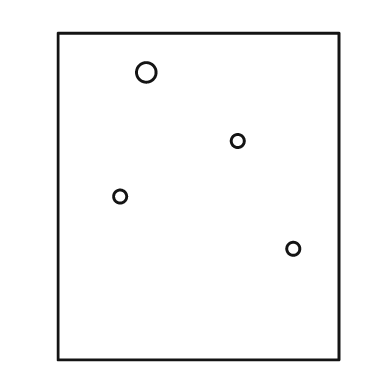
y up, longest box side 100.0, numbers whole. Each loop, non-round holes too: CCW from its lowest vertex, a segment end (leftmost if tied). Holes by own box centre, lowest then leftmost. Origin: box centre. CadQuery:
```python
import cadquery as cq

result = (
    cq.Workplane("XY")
    .moveTo(-43.0, -50.0)
    .lineTo(43.0, -50.0)
    .lineTo(43.0, 50.0)
    .lineTo(-43.0, 50.0)
    .close()
    .moveTo(29.0, -16.0)
    .circle(2.0)
    .moveTo(-24.0, 0.0)
    .circle(2.0)
    .moveTo(12.0, 17.0)
    .circle(2.0)
    .moveTo(-16.0, 38.0)
    .circle(3.0)
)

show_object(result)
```